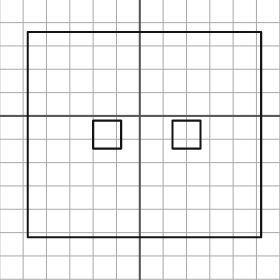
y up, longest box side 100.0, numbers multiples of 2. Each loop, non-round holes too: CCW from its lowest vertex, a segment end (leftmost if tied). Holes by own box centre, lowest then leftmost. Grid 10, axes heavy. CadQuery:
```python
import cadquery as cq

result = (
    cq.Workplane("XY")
    .moveTo(-48.0, -52.0)
    .lineTo(52.0, -52.0)
    .lineTo(52.0, 36.0)
    .lineTo(-48.0, 36.0)
    .close()
    .moveTo(-20.0, -14.0)
    .lineTo(-8.0, -14.0)
    .lineTo(-8.0, -2.0)
    .lineTo(-20.0, -2.0)
    .close()
    .moveTo(14.0, -14.0)
    .lineTo(26.0, -14.0)
    .lineTo(26.0, -2.0)
    .lineTo(14.0, -2.0)
    .close()
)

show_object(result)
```